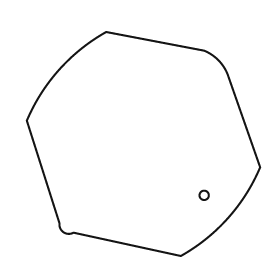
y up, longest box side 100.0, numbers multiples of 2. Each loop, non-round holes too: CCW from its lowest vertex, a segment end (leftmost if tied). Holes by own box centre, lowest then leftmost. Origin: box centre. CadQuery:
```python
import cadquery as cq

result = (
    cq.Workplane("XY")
    .moveTo(16.0, -48.0)
    .threePointArc((36.0, -32.0), (50.0, -10.0))
    .lineTo(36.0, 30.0)
    .threePointArc((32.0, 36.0), (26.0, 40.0))
    .lineTo(-16.0, 48.0)
    .threePointArc((-36.0, 32.0), (-50.0, 10.0))
    .lineTo(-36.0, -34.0)
    .threePointArc((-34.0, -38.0), (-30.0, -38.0))
    .close()
    .moveTo(26.0, -22.0)
    .circle(2.0)
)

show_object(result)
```